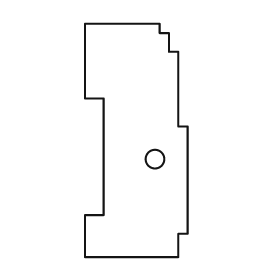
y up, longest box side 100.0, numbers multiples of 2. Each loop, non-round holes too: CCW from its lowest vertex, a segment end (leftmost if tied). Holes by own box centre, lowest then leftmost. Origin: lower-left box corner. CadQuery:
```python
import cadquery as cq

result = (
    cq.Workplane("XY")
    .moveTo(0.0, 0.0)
    .lineTo(40.0, 0.0)
    .lineTo(40.0, 10.0)
    .lineTo(44.0, 10.0)
    .lineTo(44.0, 56.0)
    .lineTo(40.0, 56.0)
    .lineTo(40.0, 88.0)
    .lineTo(36.0, 88.0)
    .lineTo(36.0, 96.0)
    .lineTo(32.0, 96.0)
    .lineTo(32.0, 100.0)
    .lineTo(0.0, 100.0)
    .lineTo(0.0, 68.0)
    .lineTo(8.0, 68.0)
    .lineTo(8.0, 18.0)
    .lineTo(0.0, 18.0)
    .close()
    .moveTo(30.0, 42.0)
    .circle(4.0)
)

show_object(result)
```